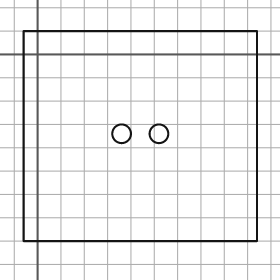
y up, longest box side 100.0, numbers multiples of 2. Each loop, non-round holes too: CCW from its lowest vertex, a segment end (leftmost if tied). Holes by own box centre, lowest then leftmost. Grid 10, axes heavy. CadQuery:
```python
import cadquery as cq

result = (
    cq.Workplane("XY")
    .moveTo(-6.0, -80.0)
    .lineTo(94.0, -80.0)
    .lineTo(94.0, 10.0)
    .lineTo(-6.0, 10.0)
    .close()
    .moveTo(36.0, -34.0)
    .circle(4.0)
    .moveTo(52.0, -34.0)
    .circle(4.0)
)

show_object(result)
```